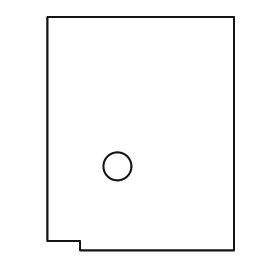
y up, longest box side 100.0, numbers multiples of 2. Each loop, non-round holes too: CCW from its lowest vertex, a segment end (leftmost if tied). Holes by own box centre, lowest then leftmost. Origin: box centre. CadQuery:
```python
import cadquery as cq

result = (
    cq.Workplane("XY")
    .moveTo(-26.0, -50.0)
    .lineTo(40.0, -50.0)
    .lineTo(40.0, 50.0)
    .lineTo(-40.0, 50.0)
    .lineTo(-40.0, -46.0)
    .lineTo(-26.0, -46.0)
    .close()
    .moveTo(-10.0, -14.0)
    .circle(6.0)
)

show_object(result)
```